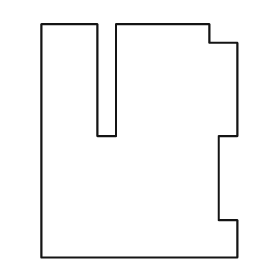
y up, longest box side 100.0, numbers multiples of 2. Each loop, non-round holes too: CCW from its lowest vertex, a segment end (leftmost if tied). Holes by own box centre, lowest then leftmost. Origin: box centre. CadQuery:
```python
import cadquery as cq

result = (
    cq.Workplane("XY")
    .moveTo(-42.0, -50.0)
    .lineTo(42.0, -50.0)
    .lineTo(42.0, -34.0)
    .lineTo(34.0, -34.0)
    .lineTo(34.0, 2.0)
    .lineTo(42.0, 2.0)
    .lineTo(42.0, 42.0)
    .lineTo(30.0, 42.0)
    .lineTo(30.0, 50.0)
    .lineTo(-10.0, 50.0)
    .lineTo(-10.0, 2.0)
    .lineTo(-18.0, 2.0)
    .lineTo(-18.0, 50.0)
    .lineTo(-42.0, 50.0)
    .close()
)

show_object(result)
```